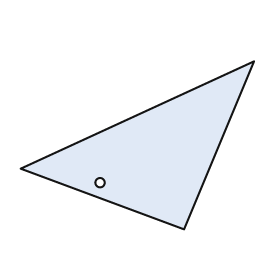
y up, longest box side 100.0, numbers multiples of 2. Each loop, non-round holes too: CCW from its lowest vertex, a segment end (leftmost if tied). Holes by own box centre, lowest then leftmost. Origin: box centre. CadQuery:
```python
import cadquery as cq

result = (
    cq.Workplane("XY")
    .moveTo(20.0, -36.0)
    .lineTo(50.0, 36.0)
    .lineTo(-50.0, -10.0)
    .close()
    .moveTo(-16.0, -16.0)
    .circle(2.0)
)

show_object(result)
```